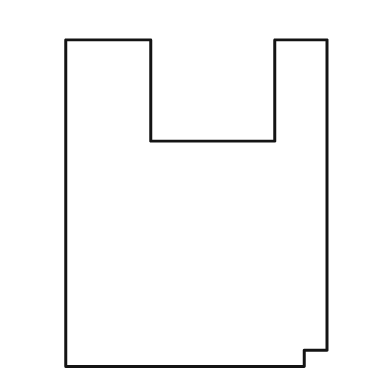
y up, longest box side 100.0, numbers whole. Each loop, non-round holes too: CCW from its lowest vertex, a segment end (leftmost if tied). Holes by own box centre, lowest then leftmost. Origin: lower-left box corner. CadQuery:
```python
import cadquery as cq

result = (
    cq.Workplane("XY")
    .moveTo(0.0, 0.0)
    .lineTo(73.0, 0.0)
    .lineTo(73.0, 5.0)
    .lineTo(80.0, 5.0)
    .lineTo(80.0, 100.0)
    .lineTo(64.0, 100.0)
    .lineTo(64.0, 69.0)
    .lineTo(26.0, 69.0)
    .lineTo(26.0, 100.0)
    .lineTo(0.0, 100.0)
    .close()
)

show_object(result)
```